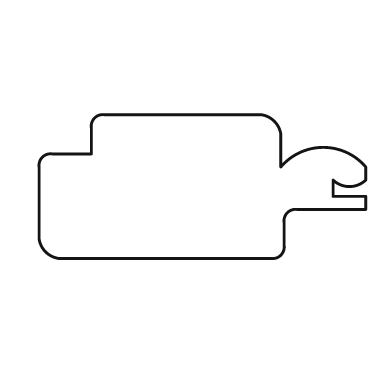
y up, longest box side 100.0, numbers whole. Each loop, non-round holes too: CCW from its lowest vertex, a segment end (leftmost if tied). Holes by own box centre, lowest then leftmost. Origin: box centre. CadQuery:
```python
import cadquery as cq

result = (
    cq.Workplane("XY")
    .moveTo(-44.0, -22.0)
    .lineTo(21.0, -22.0)
    .threePointArc((24.0, -21.0), (25.0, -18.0))
    .lineTo(25.0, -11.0)
    .threePointArc((26.0, -8.0), (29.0, -7.0))
    .lineTo(50.0, -7.0)
    .lineTo(50.0, -3.0)
    .lineTo(40.0, -3.0)
    .lineTo(40.0, 2.0)
    .threePointArc((45.0, 0.0), (50.0, 2.0))
    .lineTo(50.0, 6.0)
    .threePointArc((37.0, 12.0), (24.0, 6.0))
    .lineTo(24.0, 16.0)
    .threePointArc((22.0, 20.0), (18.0, 22.0))
    .lineTo(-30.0, 22.0)
    .threePointArc((-33.0, 21.0), (-34.0, 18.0))
    .lineTo(-34.0, 10.0)
    .lineTo(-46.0, 10.0)
    .threePointArc((-49.0, 9.0), (-50.0, 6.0))
    .lineTo(-50.0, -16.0)
    .threePointArc((-48.0, -20.0), (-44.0, -22.0))
    .close()
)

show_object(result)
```